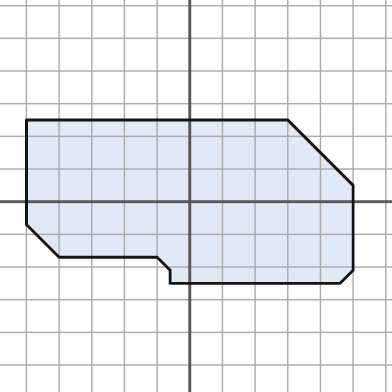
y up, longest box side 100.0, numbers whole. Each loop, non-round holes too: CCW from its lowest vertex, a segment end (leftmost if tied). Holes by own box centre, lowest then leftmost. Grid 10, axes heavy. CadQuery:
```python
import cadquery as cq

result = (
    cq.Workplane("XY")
    .moveTo(-6.0, -25.0)
    .lineTo(46.0, -25.0)
    .lineTo(50.0, -21.0)
    .lineTo(50.0, 5.0)
    .lineTo(30.0, 25.0)
    .lineTo(-50.0, 25.0)
    .lineTo(-50.0, -7.0)
    .lineTo(-40.0, -17.0)
    .lineTo(-10.0, -17.0)
    .lineTo(-6.0, -21.0)
    .close()
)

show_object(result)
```